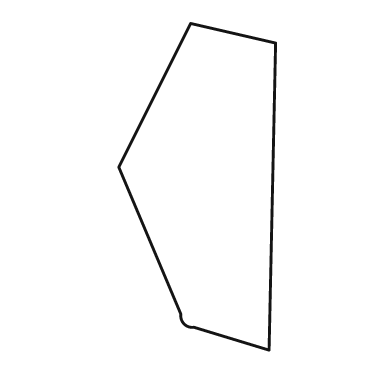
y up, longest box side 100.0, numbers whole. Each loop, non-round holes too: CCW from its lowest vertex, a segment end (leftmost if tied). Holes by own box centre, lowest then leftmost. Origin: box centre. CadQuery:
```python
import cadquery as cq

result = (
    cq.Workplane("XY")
    .moveTo(22.0, -50.0)
    .lineTo(24.0, 44.0)
    .lineTo(-2.0, 50.0)
    .lineTo(-24.0, 6.0)
    .lineTo(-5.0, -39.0)
    .threePointArc((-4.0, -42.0), (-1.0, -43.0))
    .close()
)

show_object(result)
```